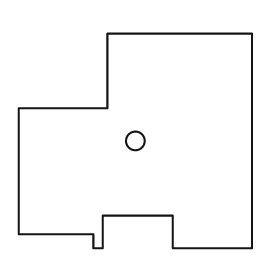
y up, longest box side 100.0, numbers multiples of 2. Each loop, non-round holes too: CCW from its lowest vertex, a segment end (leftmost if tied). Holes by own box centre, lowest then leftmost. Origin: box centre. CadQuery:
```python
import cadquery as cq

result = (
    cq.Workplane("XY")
    .moveTo(-18.0, -46.0)
    .lineTo(-14.0, -46.0)
    .lineTo(-14.0, -32.0)
    .lineTo(16.0, -32.0)
    .lineTo(16.0, -46.0)
    .lineTo(50.0, -46.0)
    .lineTo(50.0, 46.0)
    .lineTo(-12.0, 46.0)
    .lineTo(-12.0, 14.0)
    .lineTo(-50.0, 14.0)
    .lineTo(-50.0, -40.0)
    .lineTo(-18.0, -40.0)
    .close()
    .moveTo(0.0, 0.0)
    .circle(4.0)
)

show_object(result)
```